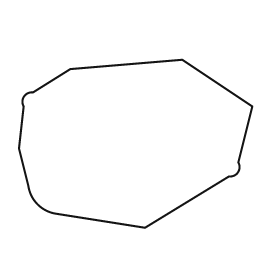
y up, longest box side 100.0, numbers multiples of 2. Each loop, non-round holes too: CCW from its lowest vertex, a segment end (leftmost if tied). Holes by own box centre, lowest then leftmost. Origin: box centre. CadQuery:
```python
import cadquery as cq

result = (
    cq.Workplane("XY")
    .moveTo(4.0, -36.0)
    .lineTo(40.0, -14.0)
    .threePointArc((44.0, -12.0), (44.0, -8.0))
    .lineTo(50.0, 16.0)
    .lineTo(20.0, 36.0)
    .lineTo(-28.0, 32.0)
    .lineTo(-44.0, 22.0)
    .threePointArc((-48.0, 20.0), (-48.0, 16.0))
    .lineTo(-50.0, -2.0)
    .lineTo(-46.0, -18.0)
    .threePointArc((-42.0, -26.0), (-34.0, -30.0))
    .close()
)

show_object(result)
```